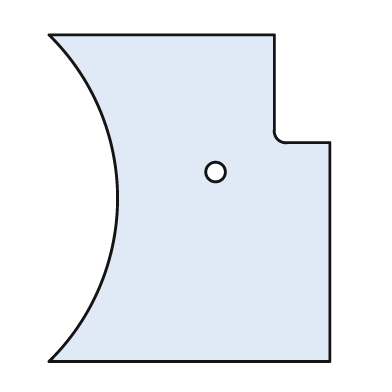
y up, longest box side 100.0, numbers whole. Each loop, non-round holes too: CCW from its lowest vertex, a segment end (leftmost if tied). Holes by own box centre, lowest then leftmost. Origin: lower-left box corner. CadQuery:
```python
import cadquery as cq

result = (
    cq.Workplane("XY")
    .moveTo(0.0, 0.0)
    .lineTo(86.0, 0.0)
    .lineTo(86.0, 67.0)
    .lineTo(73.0, 67.0)
    .threePointArc((70.0, 68.0), (69.0, 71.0))
    .lineTo(69.0, 100.0)
    .lineTo(0.0, 100.0)
    .threePointArc((21.0, 50.0), (0.0, 0.0))
    .close()
    .moveTo(51.0, 58.0)
    .circle(3.0)
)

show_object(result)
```